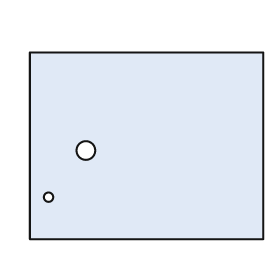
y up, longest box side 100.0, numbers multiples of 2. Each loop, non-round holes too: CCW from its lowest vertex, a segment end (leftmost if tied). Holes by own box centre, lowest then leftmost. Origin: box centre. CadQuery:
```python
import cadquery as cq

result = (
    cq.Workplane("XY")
    .moveTo(-50.0, -40.0)
    .lineTo(50.0, -40.0)
    .lineTo(50.0, 40.0)
    .lineTo(-50.0, 40.0)
    .close()
    .moveTo(-42.0, -22.0)
    .circle(2.0)
    .moveTo(-26.0, -2.0)
    .circle(4.0)
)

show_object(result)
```